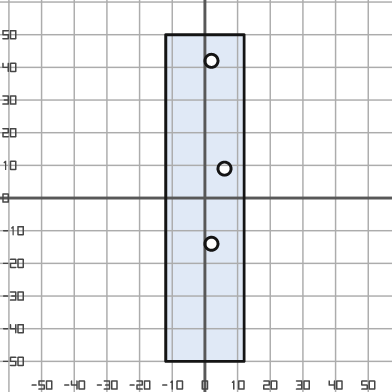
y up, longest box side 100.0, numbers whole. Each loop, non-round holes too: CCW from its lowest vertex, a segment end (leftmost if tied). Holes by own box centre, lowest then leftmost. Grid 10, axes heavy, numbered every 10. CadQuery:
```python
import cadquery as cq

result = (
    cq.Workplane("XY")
    .moveTo(-12.0, -50.0)
    .lineTo(12.0, -50.0)
    .lineTo(12.0, 50.0)
    .lineTo(-12.0, 50.0)
    .close()
    .moveTo(2.0, -14.0)
    .circle(2.0)
    .moveTo(6.0, 9.0)
    .circle(2.0)
    .moveTo(2.0, 42.0)
    .circle(2.0)
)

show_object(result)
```